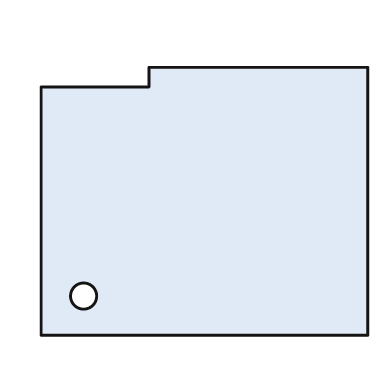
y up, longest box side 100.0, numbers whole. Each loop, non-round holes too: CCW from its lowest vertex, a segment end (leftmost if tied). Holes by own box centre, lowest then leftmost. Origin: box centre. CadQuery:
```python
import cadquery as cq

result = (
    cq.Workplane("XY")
    .moveTo(-50.0, -41.0)
    .lineTo(50.0, -41.0)
    .lineTo(50.0, 41.0)
    .lineTo(-17.0, 41.0)
    .lineTo(-17.0, 35.0)
    .lineTo(-50.0, 35.0)
    .close()
    .moveTo(-37.0, -29.0)
    .circle(4.0)
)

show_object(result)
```